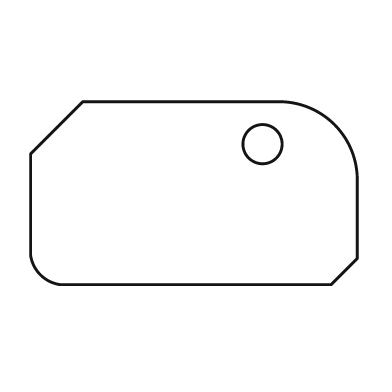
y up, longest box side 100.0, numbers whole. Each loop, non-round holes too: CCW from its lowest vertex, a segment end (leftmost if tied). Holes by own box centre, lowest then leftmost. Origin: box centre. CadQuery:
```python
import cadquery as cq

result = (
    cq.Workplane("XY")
    .moveTo(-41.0, -28.0)
    .lineTo(42.0, -28.0)
    .lineTo(50.0, -20.0)
    .lineTo(50.0, 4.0)
    .threePointArc((43.0, 21.0), (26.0, 28.0))
    .lineTo(-34.0, 28.0)
    .lineTo(-50.0, 12.0)
    .lineTo(-50.0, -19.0)
    .threePointArc((-47.0, -25.0), (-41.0, -28.0))
    .close()
    .moveTo(21.0, 15.0)
    .circle(6.0)
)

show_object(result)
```